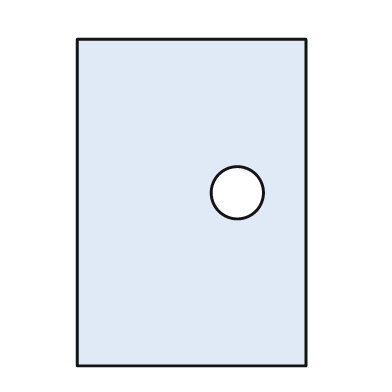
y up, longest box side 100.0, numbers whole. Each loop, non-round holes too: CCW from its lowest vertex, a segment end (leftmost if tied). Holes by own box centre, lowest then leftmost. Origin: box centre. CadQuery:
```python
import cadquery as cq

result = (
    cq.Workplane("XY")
    .moveTo(-35.0, -50.0)
    .lineTo(35.0, -50.0)
    .lineTo(35.0, 50.0)
    .lineTo(-35.0, 50.0)
    .close()
    .moveTo(14.0, 3.0)
    .circle(8.0)
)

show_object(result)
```